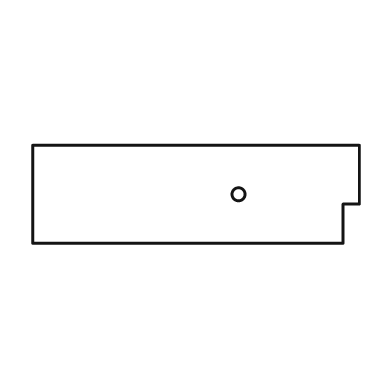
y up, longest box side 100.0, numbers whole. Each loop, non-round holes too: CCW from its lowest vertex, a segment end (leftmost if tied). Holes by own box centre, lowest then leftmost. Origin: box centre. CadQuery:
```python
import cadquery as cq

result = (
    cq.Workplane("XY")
    .moveTo(-50.0, -15.0)
    .lineTo(45.0, -15.0)
    .lineTo(45.0, -3.0)
    .lineTo(50.0, -3.0)
    .lineTo(50.0, 15.0)
    .lineTo(-50.0, 15.0)
    .close()
    .moveTo(13.0, 0.0)
    .circle(2.0)
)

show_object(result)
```